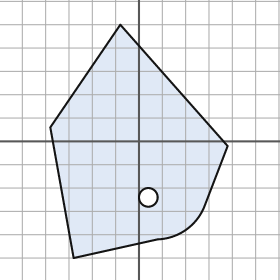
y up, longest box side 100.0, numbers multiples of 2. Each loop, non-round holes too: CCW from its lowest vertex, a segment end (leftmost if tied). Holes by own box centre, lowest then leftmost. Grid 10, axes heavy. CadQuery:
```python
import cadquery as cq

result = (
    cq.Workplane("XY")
    .moveTo(-28.0, -50.0)
    .lineTo(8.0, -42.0)
    .threePointArc((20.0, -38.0), (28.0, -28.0))
    .lineTo(38.0, -2.0)
    .lineTo(-8.0, 50.0)
    .lineTo(-38.0, 6.0)
    .close()
    .moveTo(4.0, -24.0)
    .circle(4.0)
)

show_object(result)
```